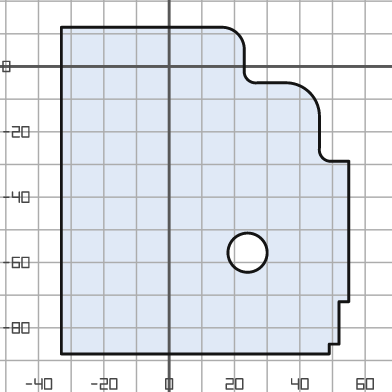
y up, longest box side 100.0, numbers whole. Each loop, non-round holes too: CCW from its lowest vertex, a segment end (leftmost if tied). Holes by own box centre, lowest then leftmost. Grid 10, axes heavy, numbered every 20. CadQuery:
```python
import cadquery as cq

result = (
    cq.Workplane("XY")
    .moveTo(-33.0, -88.0)
    .lineTo(49.0, -88.0)
    .lineTo(49.0, -85.0)
    .lineTo(52.0, -85.0)
    .lineTo(52.0, -72.0)
    .lineTo(55.0, -72.0)
    .lineTo(55.0, -29.0)
    .lineTo(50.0, -29.0)
    .threePointArc((47.0, -28.0), (46.0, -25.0))
    .lineTo(46.0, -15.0)
    .threePointArc((43.0, -8.0), (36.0, -5.0))
    .lineTo(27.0, -5.0)
    .threePointArc((24.0, -4.0), (23.0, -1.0))
    .lineTo(23.0, 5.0)
    .threePointArc((21.0, 10.0), (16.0, 12.0))
    .lineTo(-33.0, 12.0)
    .close()
    .moveTo(24.0, -57.0)
    .circle(6.0)
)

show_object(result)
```